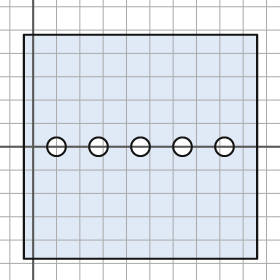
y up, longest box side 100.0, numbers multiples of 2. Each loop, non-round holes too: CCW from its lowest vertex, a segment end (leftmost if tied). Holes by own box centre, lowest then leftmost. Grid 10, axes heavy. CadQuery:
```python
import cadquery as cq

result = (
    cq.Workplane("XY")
    .moveTo(-4.0, -48.0)
    .lineTo(96.0, -48.0)
    .lineTo(96.0, 48.0)
    .lineTo(-4.0, 48.0)
    .close()
    .moveTo(10.0, 0.0)
    .circle(4.0)
    .moveTo(28.0, 0.0)
    .circle(4.0)
    .moveTo(46.0, 0.0)
    .circle(4.0)
    .moveTo(64.0, 0.0)
    .circle(4.0)
    .moveTo(82.0, 0.0)
    .circle(4.0)
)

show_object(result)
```